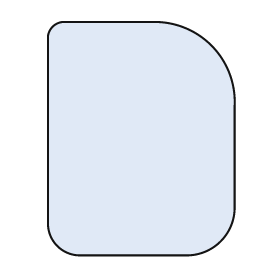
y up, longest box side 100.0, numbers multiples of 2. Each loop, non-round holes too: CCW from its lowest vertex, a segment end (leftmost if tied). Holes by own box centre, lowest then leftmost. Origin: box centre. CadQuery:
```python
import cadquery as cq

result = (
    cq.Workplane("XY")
    .moveTo(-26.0, -50.0)
    .lineTo(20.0, -50.0)
    .threePointArc((34.0, -44.0), (40.0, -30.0))
    .lineTo(40.0, 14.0)
    .threePointArc((30.0, 40.0), (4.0, 50.0))
    .lineTo(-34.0, 50.0)
    .threePointArc((-38.0, 48.0), (-40.0, 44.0))
    .lineTo(-40.0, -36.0)
    .threePointArc((-36.0, -46.0), (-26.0, -50.0))
    .close()
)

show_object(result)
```